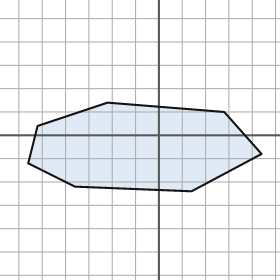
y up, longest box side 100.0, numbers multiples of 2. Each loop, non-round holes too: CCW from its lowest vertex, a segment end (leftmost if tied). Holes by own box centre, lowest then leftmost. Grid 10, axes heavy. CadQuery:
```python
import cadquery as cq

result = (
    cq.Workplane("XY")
    .moveTo(14.0, -24.0)
    .lineTo(44.0, -8.0)
    .lineTo(28.0, 10.0)
    .lineTo(-22.0, 14.0)
    .lineTo(-52.0, 4.0)
    .lineTo(-56.0, -12.0)
    .lineTo(-36.0, -22.0)
    .close()
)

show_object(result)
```